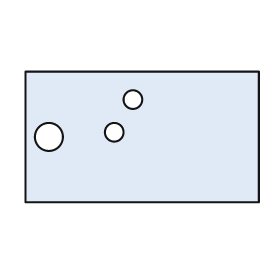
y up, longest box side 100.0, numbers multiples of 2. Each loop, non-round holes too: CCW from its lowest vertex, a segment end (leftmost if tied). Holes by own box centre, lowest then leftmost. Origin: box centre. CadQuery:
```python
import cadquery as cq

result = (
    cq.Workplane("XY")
    .moveTo(-50.0, -28.0)
    .lineTo(50.0, -28.0)
    .lineTo(50.0, 28.0)
    .lineTo(-50.0, 28.0)
    .close()
    .moveTo(-40.0, 0.0)
    .circle(6.0)
    .moveTo(-12.0, 2.0)
    .circle(4.0)
    .moveTo(-4.0, 16.0)
    .circle(4.0)
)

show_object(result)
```